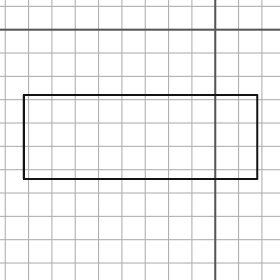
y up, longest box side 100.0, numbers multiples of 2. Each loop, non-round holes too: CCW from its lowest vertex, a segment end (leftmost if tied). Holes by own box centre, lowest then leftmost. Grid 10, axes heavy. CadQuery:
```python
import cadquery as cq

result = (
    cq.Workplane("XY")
    .moveTo(-82.0, -64.0)
    .lineTo(18.0, -64.0)
    .lineTo(18.0, -28.0)
    .lineTo(-82.0, -28.0)
    .close()
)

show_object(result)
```